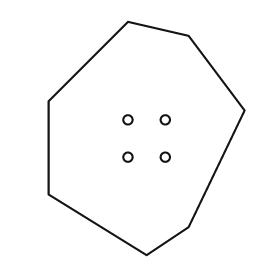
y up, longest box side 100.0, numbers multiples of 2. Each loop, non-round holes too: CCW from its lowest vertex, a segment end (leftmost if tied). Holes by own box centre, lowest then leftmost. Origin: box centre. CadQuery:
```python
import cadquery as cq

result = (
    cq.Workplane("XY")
    .moveTo(0.0, -50.0)
    .lineTo(18.0, -38.0)
    .lineTo(42.0, 12.0)
    .lineTo(18.0, 44.0)
    .lineTo(-8.0, 50.0)
    .lineTo(-42.0, 16.0)
    .lineTo(-42.0, -24.0)
    .close()
    .moveTo(-8.0, -8.0)
    .circle(2.0)
    .moveTo(8.0, -8.0)
    .circle(2.0)
    .moveTo(-8.0, 8.0)
    .circle(2.0)
    .moveTo(8.0, 8.0)
    .circle(2.0)
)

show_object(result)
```